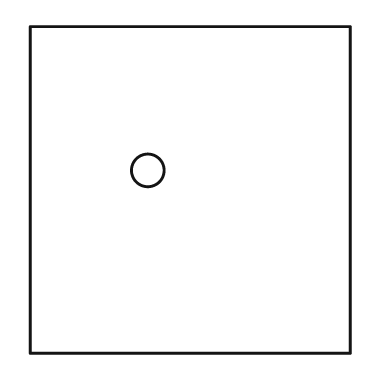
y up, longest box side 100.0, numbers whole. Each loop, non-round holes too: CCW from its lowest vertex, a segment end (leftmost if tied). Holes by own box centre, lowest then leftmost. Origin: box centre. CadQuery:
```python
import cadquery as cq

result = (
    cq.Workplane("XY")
    .moveTo(-49.0, -50.0)
    .lineTo(49.0, -50.0)
    .lineTo(49.0, 50.0)
    .lineTo(-49.0, 50.0)
    .close()
    .moveTo(-13.0, 6.0)
    .circle(5.0)
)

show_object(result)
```